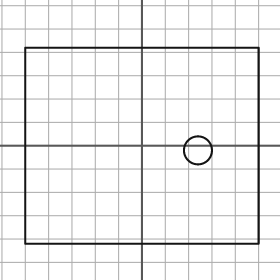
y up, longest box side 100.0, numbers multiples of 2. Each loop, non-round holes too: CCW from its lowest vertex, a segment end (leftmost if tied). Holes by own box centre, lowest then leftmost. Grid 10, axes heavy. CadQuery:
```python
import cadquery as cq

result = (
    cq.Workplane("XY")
    .moveTo(-50.0, -42.0)
    .lineTo(50.0, -42.0)
    .lineTo(50.0, 42.0)
    .lineTo(-50.0, 42.0)
    .close()
    .moveTo(24.0, -2.0)
    .circle(6.0)
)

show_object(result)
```